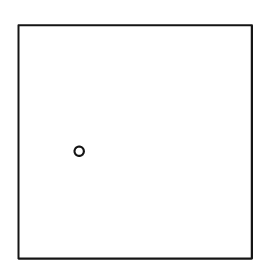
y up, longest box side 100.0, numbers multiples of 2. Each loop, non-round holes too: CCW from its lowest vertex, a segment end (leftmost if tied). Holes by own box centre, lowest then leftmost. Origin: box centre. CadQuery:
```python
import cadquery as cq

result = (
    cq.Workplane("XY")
    .moveTo(-50.0, -50.0)
    .lineTo(50.0, -50.0)
    .lineTo(50.0, 50.0)
    .lineTo(-50.0, 50.0)
    .close()
    .moveTo(-24.0, -4.0)
    .circle(2.0)
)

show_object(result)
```